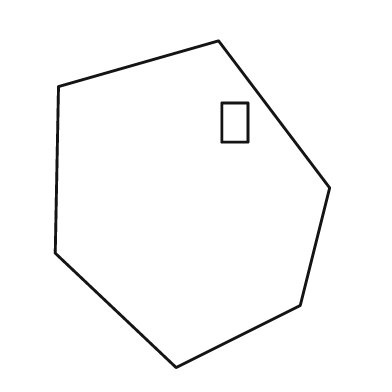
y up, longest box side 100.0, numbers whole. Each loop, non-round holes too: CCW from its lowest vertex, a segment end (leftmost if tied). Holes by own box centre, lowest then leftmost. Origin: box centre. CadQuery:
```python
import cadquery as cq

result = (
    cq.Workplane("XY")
    .moveTo(-5.0, -50.0)
    .lineTo(33.0, -31.0)
    .lineTo(42.0, 5.0)
    .lineTo(8.0, 50.0)
    .lineTo(-41.0, 36.0)
    .lineTo(-42.0, -15.0)
    .close()
    .moveTo(9.0, 19.0)
    .lineTo(17.0, 19.0)
    .lineTo(17.0, 31.0)
    .lineTo(9.0, 31.0)
    .close()
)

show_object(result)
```